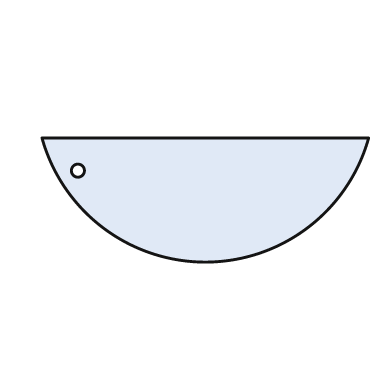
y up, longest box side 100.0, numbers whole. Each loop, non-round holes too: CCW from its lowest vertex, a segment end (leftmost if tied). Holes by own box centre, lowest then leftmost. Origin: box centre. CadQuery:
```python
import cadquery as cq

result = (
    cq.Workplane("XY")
    .moveTo(-50.0, 19.0)
    .threePointArc((0.0, -19.0), (50.0, 19.0))
    .close()
    .moveTo(-39.0, 9.0)
    .circle(2.0)
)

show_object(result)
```